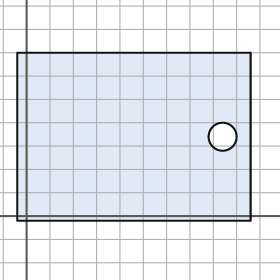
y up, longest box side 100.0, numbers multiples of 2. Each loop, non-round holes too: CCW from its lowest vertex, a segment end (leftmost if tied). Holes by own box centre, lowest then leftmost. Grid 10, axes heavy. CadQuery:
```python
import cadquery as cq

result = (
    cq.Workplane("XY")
    .moveTo(-4.0, -2.0)
    .lineTo(96.0, -2.0)
    .lineTo(96.0, 70.0)
    .lineTo(-4.0, 70.0)
    .close()
    .moveTo(84.0, 34.0)
    .circle(6.0)
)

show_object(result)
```